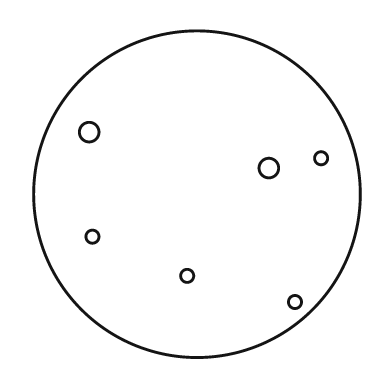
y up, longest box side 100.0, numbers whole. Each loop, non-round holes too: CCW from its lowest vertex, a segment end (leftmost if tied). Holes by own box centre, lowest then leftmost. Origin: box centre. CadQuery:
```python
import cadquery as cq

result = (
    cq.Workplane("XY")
    .moveTo(0.0, 0.0)
    .circle(50.0)
    .moveTo(30.0, -33.0)
    .circle(2.0)
    .moveTo(-3.0, -25.0)
    .circle(2.0)
    .moveTo(-32.0, -13.0)
    .circle(2.0)
    .moveTo(22.0, 8.0)
    .circle(3.0)
    .moveTo(38.0, 11.0)
    .circle(2.0)
    .moveTo(-33.0, 19.0)
    .circle(3.0)
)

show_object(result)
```